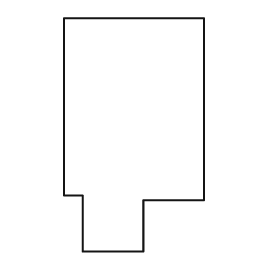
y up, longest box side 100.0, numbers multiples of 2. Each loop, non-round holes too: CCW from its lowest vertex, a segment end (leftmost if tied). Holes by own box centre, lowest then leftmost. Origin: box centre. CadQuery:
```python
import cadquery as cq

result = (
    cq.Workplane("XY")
    .moveTo(-22.0, -50.0)
    .lineTo(4.0, -50.0)
    .lineTo(4.0, -28.0)
    .lineTo(30.0, -28.0)
    .lineTo(30.0, 50.0)
    .lineTo(-30.0, 50.0)
    .lineTo(-30.0, -26.0)
    .lineTo(-22.0, -26.0)
    .close()
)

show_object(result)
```